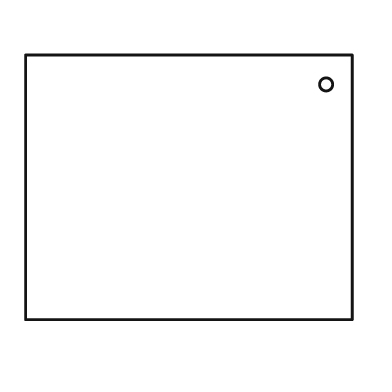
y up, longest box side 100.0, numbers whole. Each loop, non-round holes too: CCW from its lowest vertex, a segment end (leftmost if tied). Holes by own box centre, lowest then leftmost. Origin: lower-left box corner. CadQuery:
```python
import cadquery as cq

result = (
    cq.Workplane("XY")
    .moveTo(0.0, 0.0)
    .lineTo(100.0, 0.0)
    .lineTo(100.0, 81.0)
    .lineTo(0.0, 81.0)
    .close()
    .moveTo(92.0, 72.0)
    .circle(2.0)
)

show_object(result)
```